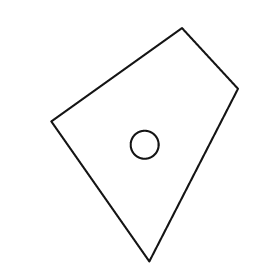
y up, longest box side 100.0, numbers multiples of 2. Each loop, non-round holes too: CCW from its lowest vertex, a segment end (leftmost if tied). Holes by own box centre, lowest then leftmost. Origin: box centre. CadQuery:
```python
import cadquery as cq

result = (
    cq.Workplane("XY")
    .moveTo(2.0, -50.0)
    .lineTo(40.0, 24.0)
    .lineTo(16.0, 50.0)
    .lineTo(-40.0, 10.0)
    .close()
    .moveTo(0.0, 0.0)
    .circle(6.0)
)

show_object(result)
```